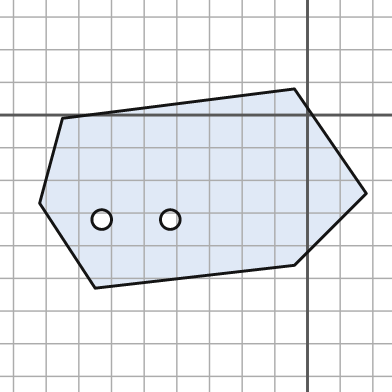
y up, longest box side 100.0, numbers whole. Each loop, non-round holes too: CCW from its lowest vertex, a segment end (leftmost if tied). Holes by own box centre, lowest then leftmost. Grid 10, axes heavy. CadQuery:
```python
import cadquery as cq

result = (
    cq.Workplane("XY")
    .moveTo(-65.0, -53.0)
    .lineTo(-4.0, -46.0)
    .lineTo(18.0, -24.0)
    .lineTo(-4.0, 8.0)
    .lineTo(-75.0, -1.0)
    .lineTo(-82.0, -27.0)
    .close()
    .moveTo(-63.0, -32.0)
    .circle(3.0)
    .moveTo(-42.0, -32.0)
    .circle(3.0)
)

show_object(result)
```